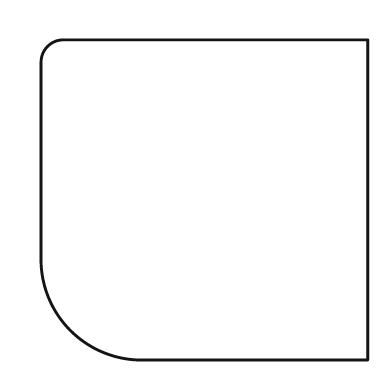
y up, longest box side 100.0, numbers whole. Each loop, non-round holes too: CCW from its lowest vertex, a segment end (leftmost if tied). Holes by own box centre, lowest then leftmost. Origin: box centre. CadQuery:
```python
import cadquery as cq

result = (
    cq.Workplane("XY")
    .moveTo(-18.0, -49.0)
    .lineTo(50.0, -49.0)
    .lineTo(50.0, 49.0)
    .lineTo(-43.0, 49.0)
    .threePointArc((-48.0, 47.0), (-50.0, 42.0))
    .lineTo(-50.0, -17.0)
    .threePointArc((-41.0, -40.0), (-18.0, -49.0))
    .close()
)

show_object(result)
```